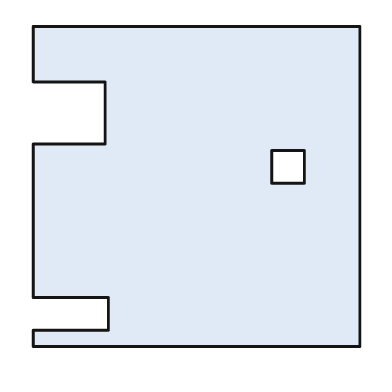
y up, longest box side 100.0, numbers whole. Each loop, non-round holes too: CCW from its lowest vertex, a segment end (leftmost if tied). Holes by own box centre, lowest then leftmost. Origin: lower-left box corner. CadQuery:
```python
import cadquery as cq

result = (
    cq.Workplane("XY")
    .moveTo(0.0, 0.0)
    .lineTo(100.0, 0.0)
    .lineTo(100.0, 98.0)
    .lineTo(0.0, 98.0)
    .lineTo(0.0, 81.0)
    .lineTo(22.0, 81.0)
    .lineTo(22.0, 62.0)
    .lineTo(0.0, 62.0)
    .lineTo(0.0, 15.0)
    .lineTo(23.0, 15.0)
    .lineTo(23.0, 5.0)
    .lineTo(0.0, 5.0)
    .close()
    .moveTo(73.0, 50.0)
    .lineTo(83.0, 50.0)
    .lineTo(83.0, 60.0)
    .lineTo(73.0, 60.0)
    .close()
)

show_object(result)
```